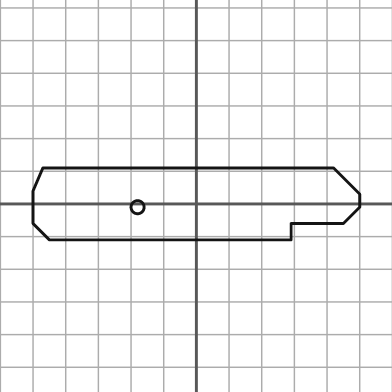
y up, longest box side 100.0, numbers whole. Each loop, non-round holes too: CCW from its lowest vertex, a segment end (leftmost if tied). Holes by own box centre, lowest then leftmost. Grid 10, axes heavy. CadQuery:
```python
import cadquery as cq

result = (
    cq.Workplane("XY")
    .moveTo(-45.0, -11.0)
    .lineTo(29.0, -11.0)
    .lineTo(29.0, -6.0)
    .lineTo(45.0, -6.0)
    .lineTo(50.0, -1.0)
    .lineTo(50.0, 3.0)
    .lineTo(42.0, 11.0)
    .lineTo(-47.0, 11.0)
    .lineTo(-50.0, 4.0)
    .lineTo(-50.0, -6.0)
    .close()
    .moveTo(-18.0, -1.0)
    .circle(2.0)
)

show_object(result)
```